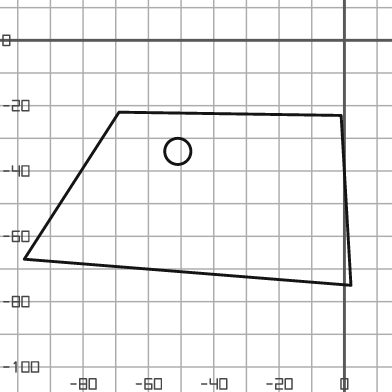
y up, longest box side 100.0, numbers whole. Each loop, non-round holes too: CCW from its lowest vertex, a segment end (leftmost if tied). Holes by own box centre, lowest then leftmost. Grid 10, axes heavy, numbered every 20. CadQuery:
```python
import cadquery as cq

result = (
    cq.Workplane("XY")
    .moveTo(2.0, -75.0)
    .lineTo(-1.0, -23.0)
    .lineTo(-69.0, -22.0)
    .lineTo(-98.0, -67.0)
    .close()
    .moveTo(-51.0, -34.0)
    .circle(4.0)
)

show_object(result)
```